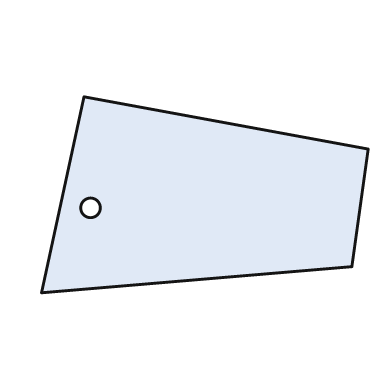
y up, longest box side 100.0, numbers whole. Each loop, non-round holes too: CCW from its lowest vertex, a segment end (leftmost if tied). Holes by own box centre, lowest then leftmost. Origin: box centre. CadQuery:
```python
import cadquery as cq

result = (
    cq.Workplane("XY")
    .moveTo(-50.0, -30.0)
    .lineTo(45.0, -22.0)
    .lineTo(50.0, 14.0)
    .lineTo(-37.0, 30.0)
    .close()
    .moveTo(-35.0, -4.0)
    .circle(3.0)
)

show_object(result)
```